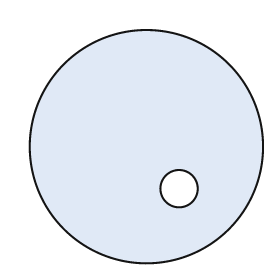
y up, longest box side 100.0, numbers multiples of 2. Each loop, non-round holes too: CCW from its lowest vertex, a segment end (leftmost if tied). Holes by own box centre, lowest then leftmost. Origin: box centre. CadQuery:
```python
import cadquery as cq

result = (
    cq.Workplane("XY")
    .moveTo(0.0, 0.0)
    .circle(50.0)
    .moveTo(14.0, -18.0)
    .circle(8.0)
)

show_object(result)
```